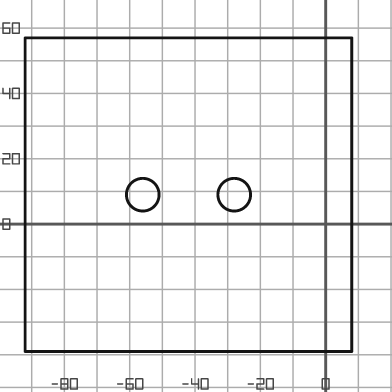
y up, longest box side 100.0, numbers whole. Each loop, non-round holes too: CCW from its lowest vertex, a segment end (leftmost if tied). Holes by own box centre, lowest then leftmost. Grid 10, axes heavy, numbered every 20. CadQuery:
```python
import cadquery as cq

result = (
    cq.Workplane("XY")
    .moveTo(-92.0, -39.0)
    .lineTo(8.0, -39.0)
    .lineTo(8.0, 57.0)
    .lineTo(-92.0, 57.0)
    .close()
    .moveTo(-56.0, 9.0)
    .circle(5.0)
    .moveTo(-28.0, 9.0)
    .circle(5.0)
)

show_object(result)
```